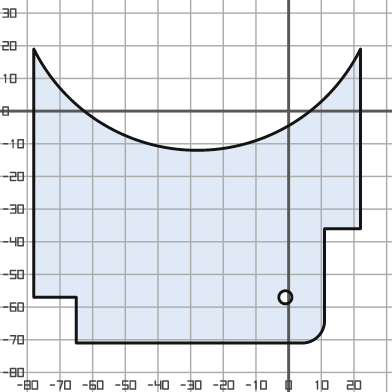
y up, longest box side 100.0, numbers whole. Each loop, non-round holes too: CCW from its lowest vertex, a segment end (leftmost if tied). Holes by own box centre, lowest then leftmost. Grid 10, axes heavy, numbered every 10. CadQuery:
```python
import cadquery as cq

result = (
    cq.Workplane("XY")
    .moveTo(-65.0, -71.0)
    .lineTo(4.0, -71.0)
    .threePointArc((9.0, -69.0), (11.0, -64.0))
    .lineTo(11.0, -36.0)
    .lineTo(22.0, -36.0)
    .lineTo(22.0, 19.0)
    .threePointArc((-28.0, -12.0), (-78.0, 19.0))
    .lineTo(-78.0, -57.0)
    .lineTo(-65.0, -57.0)
    .close()
    .moveTo(-1.0, -57.0)
    .circle(2.0)
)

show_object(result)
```